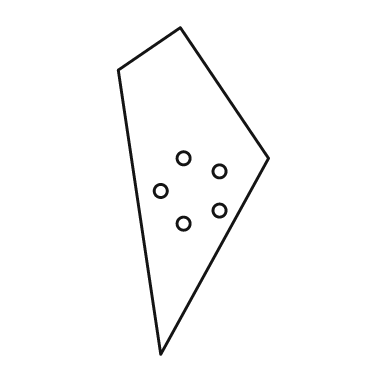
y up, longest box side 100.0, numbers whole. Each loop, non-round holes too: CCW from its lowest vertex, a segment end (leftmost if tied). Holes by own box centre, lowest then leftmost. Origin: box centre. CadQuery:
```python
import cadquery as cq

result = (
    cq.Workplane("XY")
    .moveTo(-10.0, -50.0)
    .lineTo(23.0, 10.0)
    .lineTo(-4.0, 50.0)
    .lineTo(-23.0, 37.0)
    .close()
    .moveTo(-3.0, -10.0)
    .circle(2.0)
    .moveTo(8.0, -6.0)
    .circle(2.0)
    .moveTo(-10.0, 0.0)
    .circle(2.0)
    .moveTo(8.0, 6.0)
    .circle(2.0)
    .moveTo(-3.0, 10.0)
    .circle(2.0)
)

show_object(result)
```